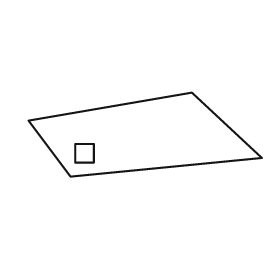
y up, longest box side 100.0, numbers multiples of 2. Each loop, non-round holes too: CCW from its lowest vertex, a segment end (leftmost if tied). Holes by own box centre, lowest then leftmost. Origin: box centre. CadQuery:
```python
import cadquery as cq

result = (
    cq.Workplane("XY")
    .moveTo(-32.0, -18.0)
    .lineTo(50.0, -10.0)
    .lineTo(20.0, 18.0)
    .lineTo(-50.0, 6.0)
    .close()
    .moveTo(-30.0, -12.0)
    .lineTo(-22.0, -12.0)
    .lineTo(-22.0, -4.0)
    .lineTo(-30.0, -4.0)
    .close()
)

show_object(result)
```